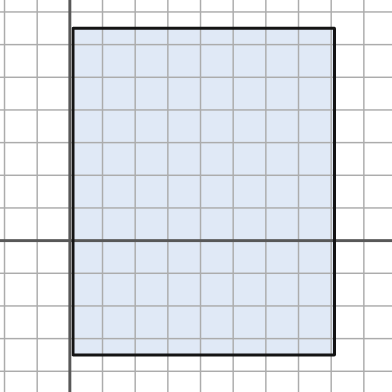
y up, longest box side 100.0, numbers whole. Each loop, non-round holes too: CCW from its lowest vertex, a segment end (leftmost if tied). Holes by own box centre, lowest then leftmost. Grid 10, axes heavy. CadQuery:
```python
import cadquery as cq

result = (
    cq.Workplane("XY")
    .moveTo(1.0, -35.0)
    .lineTo(81.0, -35.0)
    .lineTo(81.0, 65.0)
    .lineTo(1.0, 65.0)
    .close()
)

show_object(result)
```